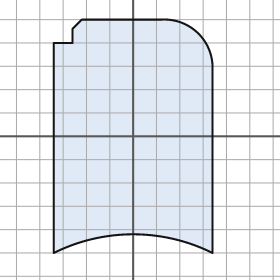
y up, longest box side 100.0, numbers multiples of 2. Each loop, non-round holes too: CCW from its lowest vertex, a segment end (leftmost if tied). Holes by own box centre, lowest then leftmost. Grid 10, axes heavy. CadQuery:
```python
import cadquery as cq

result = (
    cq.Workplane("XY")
    .moveTo(-34.0, -50.0)
    .threePointArc((0.0, -42.0), (34.0, -50.0))
    .lineTo(34.0, 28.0)
    .threePointArc((28.0, 44.0), (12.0, 50.0))
    .lineTo(-22.0, 50.0)
    .lineTo(-26.0, 46.0)
    .lineTo(-26.0, 40.0)
    .lineTo(-34.0, 40.0)
    .close()
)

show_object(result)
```